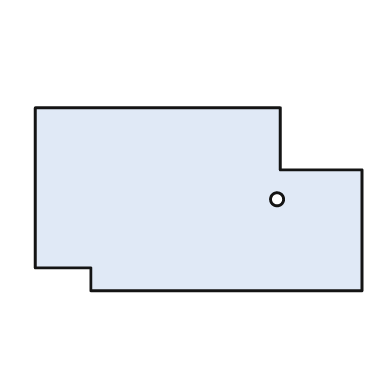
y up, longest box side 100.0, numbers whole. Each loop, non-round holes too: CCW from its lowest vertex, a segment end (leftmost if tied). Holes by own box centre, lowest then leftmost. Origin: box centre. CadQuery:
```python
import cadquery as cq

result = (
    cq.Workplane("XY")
    .moveTo(-33.0, -28.0)
    .lineTo(50.0, -28.0)
    .lineTo(50.0, 9.0)
    .lineTo(25.0, 9.0)
    .lineTo(25.0, 28.0)
    .lineTo(-50.0, 28.0)
    .lineTo(-50.0, -21.0)
    .lineTo(-33.0, -21.0)
    .close()
    .moveTo(24.0, 0.0)
    .circle(2.0)
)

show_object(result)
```